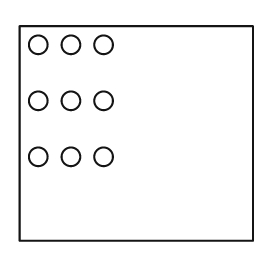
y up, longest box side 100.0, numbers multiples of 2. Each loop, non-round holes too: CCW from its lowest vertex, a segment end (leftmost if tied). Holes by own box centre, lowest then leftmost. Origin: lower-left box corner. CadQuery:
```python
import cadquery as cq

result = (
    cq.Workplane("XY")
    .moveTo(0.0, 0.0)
    .lineTo(100.0, 0.0)
    .lineTo(100.0, 92.0)
    .lineTo(0.0, 92.0)
    .close()
    .moveTo(8.0, 36.0)
    .circle(4.0)
    .moveTo(22.0, 36.0)
    .circle(4.0)
    .moveTo(36.0, 36.0)
    .circle(4.0)
    .moveTo(8.0, 60.0)
    .circle(4.0)
    .moveTo(22.0, 60.0)
    .circle(4.0)
    .moveTo(36.0, 60.0)
    .circle(4.0)
    .moveTo(8.0, 84.0)
    .circle(4.0)
    .moveTo(22.0, 84.0)
    .circle(4.0)
    .moveTo(36.0, 84.0)
    .circle(4.0)
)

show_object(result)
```